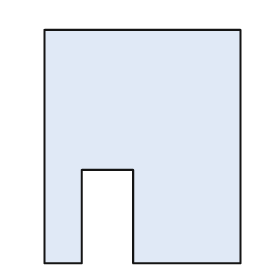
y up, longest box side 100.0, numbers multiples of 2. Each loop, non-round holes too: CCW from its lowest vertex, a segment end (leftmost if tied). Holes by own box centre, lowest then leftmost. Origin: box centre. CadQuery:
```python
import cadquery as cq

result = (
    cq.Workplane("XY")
    .moveTo(-42.0, -50.0)
    .lineTo(-26.0, -50.0)
    .lineTo(-26.0, -10.0)
    .lineTo(-4.0, -10.0)
    .lineTo(-4.0, -50.0)
    .lineTo(42.0, -50.0)
    .lineTo(42.0, 50.0)
    .lineTo(-42.0, 50.0)
    .close()
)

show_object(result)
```